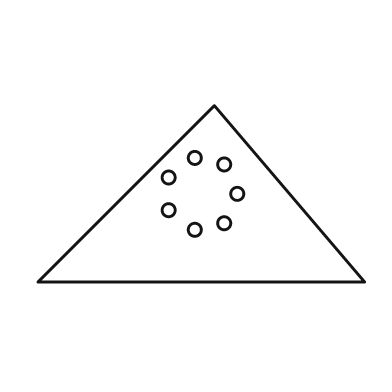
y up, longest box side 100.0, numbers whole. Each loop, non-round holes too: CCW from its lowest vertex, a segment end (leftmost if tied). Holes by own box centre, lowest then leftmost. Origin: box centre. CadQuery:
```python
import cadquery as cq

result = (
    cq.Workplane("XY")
    .moveTo(-50.0, -27.0)
    .lineTo(50.0, -27.0)
    .lineTo(4.0, 27.0)
    .close()
    .moveTo(-2.0, -11.0)
    .circle(2.0)
    .moveTo(7.0, -9.0)
    .circle(2.0)
    .moveTo(-10.0, -5.0)
    .circle(2.0)
    .moveTo(11.0, 0.0)
    .circle(2.0)
    .moveTo(-10.0, 5.0)
    .circle(2.0)
    .moveTo(7.0, 9.0)
    .circle(2.0)
    .moveTo(-2.0, 11.0)
    .circle(2.0)
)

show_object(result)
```